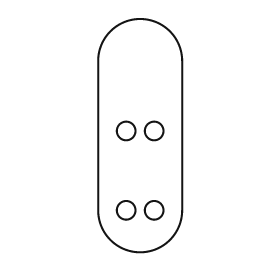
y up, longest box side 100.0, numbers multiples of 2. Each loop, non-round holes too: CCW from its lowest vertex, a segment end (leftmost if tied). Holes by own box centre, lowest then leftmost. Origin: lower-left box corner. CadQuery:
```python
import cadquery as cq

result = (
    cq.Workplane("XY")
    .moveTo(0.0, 18.0)
    .threePointArc((18.0, 0.0), (36.0, 18.0))
    .lineTo(36.0, 82.0)
    .threePointArc((18.0, 100.0), (0.0, 82.0))
    .close()
    .moveTo(12.0, 18.0)
    .circle(4.0)
    .moveTo(24.0, 18.0)
    .circle(4.0)
    .moveTo(12.0, 52.0)
    .circle(4.0)
    .moveTo(24.0, 52.0)
    .circle(4.0)
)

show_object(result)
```